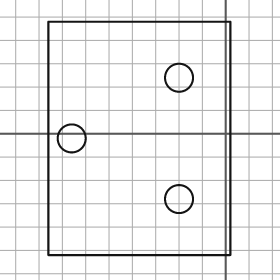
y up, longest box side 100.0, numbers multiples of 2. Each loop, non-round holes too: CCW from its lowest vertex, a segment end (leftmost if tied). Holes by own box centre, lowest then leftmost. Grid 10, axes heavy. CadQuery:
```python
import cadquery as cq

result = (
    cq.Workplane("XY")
    .moveTo(-76.0, -52.0)
    .lineTo(2.0, -52.0)
    .lineTo(2.0, 48.0)
    .lineTo(-76.0, 48.0)
    .close()
    .moveTo(-20.0, -28.0)
    .circle(6.0)
    .moveTo(-66.0, -2.0)
    .circle(6.0)
    .moveTo(-20.0, 24.0)
    .circle(6.0)
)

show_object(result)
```